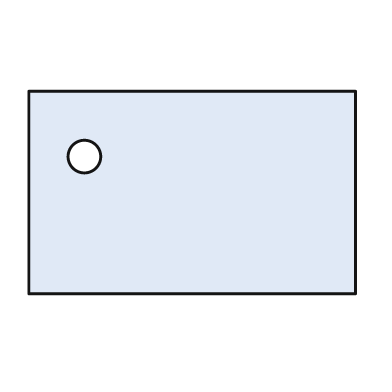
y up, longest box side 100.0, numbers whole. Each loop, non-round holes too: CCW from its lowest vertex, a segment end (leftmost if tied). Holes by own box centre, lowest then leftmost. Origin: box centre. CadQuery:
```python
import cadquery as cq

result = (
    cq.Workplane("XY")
    .moveTo(-50.0, -31.0)
    .lineTo(50.0, -31.0)
    .lineTo(50.0, 31.0)
    .lineTo(-50.0, 31.0)
    .close()
    .moveTo(-33.0, 11.0)
    .circle(5.0)
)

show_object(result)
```